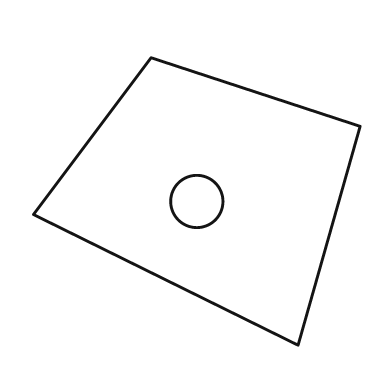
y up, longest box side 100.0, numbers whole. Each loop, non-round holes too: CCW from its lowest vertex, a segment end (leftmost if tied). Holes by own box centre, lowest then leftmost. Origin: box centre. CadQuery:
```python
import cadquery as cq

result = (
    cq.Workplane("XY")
    .moveTo(31.0, -44.0)
    .lineTo(50.0, 23.0)
    .lineTo(-14.0, 44.0)
    .lineTo(-50.0, -4.0)
    .close()
    .moveTo(0.0, 0.0)
    .circle(8.0)
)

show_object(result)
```